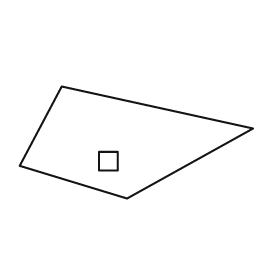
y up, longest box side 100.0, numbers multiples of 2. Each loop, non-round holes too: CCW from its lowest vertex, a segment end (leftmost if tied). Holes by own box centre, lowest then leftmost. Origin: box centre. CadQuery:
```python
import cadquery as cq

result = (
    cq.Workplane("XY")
    .moveTo(-4.0, -24.0)
    .lineTo(50.0, 6.0)
    .lineTo(-32.0, 24.0)
    .lineTo(-50.0, -10.0)
    .close()
    .moveTo(-16.0, -12.0)
    .lineTo(-8.0, -12.0)
    .lineTo(-8.0, -4.0)
    .lineTo(-16.0, -4.0)
    .close()
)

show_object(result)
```